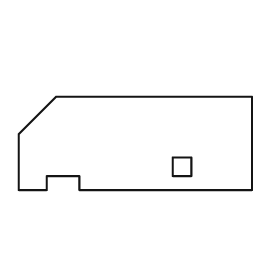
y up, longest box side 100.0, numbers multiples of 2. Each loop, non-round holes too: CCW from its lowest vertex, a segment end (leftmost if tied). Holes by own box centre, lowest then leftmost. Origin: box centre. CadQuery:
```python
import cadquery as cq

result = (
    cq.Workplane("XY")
    .moveTo(-50.0, -20.0)
    .lineTo(-38.0, -20.0)
    .lineTo(-38.0, -14.0)
    .lineTo(-24.0, -14.0)
    .lineTo(-24.0, -20.0)
    .lineTo(50.0, -20.0)
    .lineTo(50.0, 20.0)
    .lineTo(-34.0, 20.0)
    .lineTo(-50.0, 4.0)
    .close()
    .moveTo(16.0, -14.0)
    .lineTo(24.0, -14.0)
    .lineTo(24.0, -6.0)
    .lineTo(16.0, -6.0)
    .close()
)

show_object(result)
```